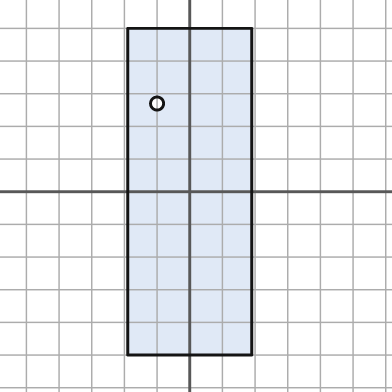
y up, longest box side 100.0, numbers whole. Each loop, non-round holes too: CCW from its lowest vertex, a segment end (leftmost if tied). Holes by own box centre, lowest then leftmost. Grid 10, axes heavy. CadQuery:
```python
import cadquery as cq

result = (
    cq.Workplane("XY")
    .moveTo(-19.0, -50.0)
    .lineTo(19.0, -50.0)
    .lineTo(19.0, 50.0)
    .lineTo(-19.0, 50.0)
    .close()
    .moveTo(-10.0, 27.0)
    .circle(2.0)
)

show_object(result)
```